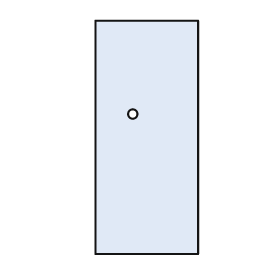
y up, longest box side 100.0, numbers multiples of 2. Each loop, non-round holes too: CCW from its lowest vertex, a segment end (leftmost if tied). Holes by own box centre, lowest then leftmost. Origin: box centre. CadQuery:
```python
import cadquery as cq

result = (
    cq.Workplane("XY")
    .moveTo(-22.0, -50.0)
    .lineTo(22.0, -50.0)
    .lineTo(22.0, 50.0)
    .lineTo(-22.0, 50.0)
    .close()
    .moveTo(-6.0, 10.0)
    .circle(2.0)
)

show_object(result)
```